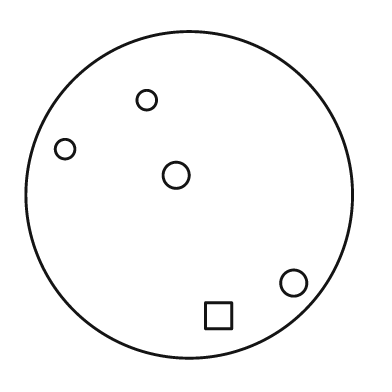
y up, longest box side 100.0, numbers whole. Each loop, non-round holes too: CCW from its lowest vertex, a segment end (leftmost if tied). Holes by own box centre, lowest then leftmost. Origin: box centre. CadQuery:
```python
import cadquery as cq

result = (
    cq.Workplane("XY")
    .moveTo(0.0, 0.0)
    .circle(50.0)
    .moveTo(5.0, -41.0)
    .lineTo(13.0, -41.0)
    .lineTo(13.0, -33.0)
    .lineTo(5.0, -33.0)
    .close()
    .moveTo(32.0, -27.0)
    .circle(4.0)
    .moveTo(-4.0, 6.0)
    .circle(4.0)
    .moveTo(-38.0, 14.0)
    .circle(3.0)
    .moveTo(-13.0, 29.0)
    .circle(3.0)
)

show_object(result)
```